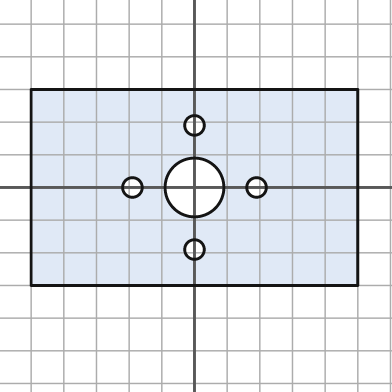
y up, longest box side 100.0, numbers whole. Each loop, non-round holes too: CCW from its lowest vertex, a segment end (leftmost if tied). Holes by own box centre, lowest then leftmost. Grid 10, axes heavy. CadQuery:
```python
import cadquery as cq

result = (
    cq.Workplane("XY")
    .moveTo(-50.0, -30.0)
    .lineTo(50.0, -30.0)
    .lineTo(50.0, 30.0)
    .lineTo(-50.0, 30.0)
    .close()
    .moveTo(0.0, -19.0)
    .circle(3.0)
    .moveTo(-19.0, 0.0)
    .circle(3.0)
    .moveTo(0.0, 0.0)
    .circle(9.0)
    .moveTo(19.0, 0.0)
    .circle(3.0)
    .moveTo(0.0, 19.0)
    .circle(3.0)
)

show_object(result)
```